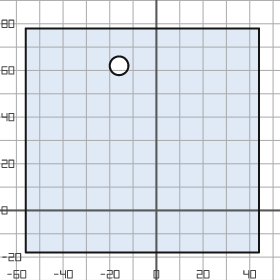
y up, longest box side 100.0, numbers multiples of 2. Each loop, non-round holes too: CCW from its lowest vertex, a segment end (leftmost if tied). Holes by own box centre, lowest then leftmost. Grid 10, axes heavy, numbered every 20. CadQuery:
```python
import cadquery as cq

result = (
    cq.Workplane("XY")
    .moveTo(-56.0, -18.0)
    .lineTo(44.0, -18.0)
    .lineTo(44.0, 78.0)
    .lineTo(-56.0, 78.0)
    .close()
    .moveTo(-16.0, 62.0)
    .circle(4.0)
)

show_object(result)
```